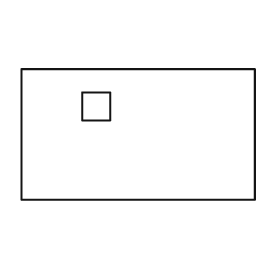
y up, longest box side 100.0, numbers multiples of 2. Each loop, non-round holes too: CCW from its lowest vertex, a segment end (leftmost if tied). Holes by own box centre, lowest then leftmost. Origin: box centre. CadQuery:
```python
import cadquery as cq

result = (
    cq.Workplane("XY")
    .moveTo(-50.0, -28.0)
    .lineTo(50.0, -28.0)
    .lineTo(50.0, 28.0)
    .lineTo(-50.0, 28.0)
    .close()
    .moveTo(-24.0, 6.0)
    .lineTo(-12.0, 6.0)
    .lineTo(-12.0, 18.0)
    .lineTo(-24.0, 18.0)
    .close()
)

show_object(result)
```